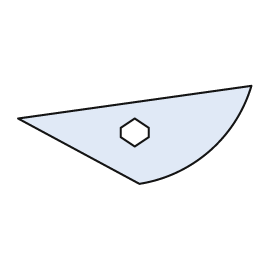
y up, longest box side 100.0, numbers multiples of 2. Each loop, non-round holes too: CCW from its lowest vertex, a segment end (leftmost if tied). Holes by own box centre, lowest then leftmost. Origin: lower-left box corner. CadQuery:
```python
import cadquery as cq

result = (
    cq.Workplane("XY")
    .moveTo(52.0, 0.0)
    .threePointArc((82.0, 14.0), (100.0, 42.0))
    .lineTo(0.0, 28.0)
    .close()
    .moveTo(50.0, 16.0)
    .lineTo(56.0, 20.0)
    .lineTo(56.0, 24.0)
    .lineTo(50.0, 28.0)
    .lineTo(44.0, 24.0)
    .lineTo(44.0, 20.0)
    .close()
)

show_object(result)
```